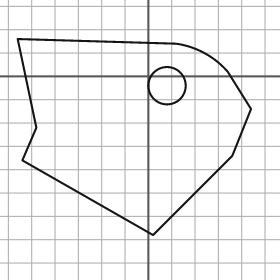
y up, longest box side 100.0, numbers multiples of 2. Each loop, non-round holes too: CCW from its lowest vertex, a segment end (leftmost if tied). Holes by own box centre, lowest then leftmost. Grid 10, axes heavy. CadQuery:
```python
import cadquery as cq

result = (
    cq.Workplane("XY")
    .moveTo(2.0, -68.0)
    .lineTo(36.0, -34.0)
    .lineTo(44.0, -14.0)
    .lineTo(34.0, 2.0)
    .threePointArc((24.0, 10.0), (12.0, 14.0))
    .lineTo(-56.0, 16.0)
    .lineTo(-48.0, -22.0)
    .lineTo(-54.0, -36.0)
    .close()
    .moveTo(8.0, -4.0)
    .circle(8.0)
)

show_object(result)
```